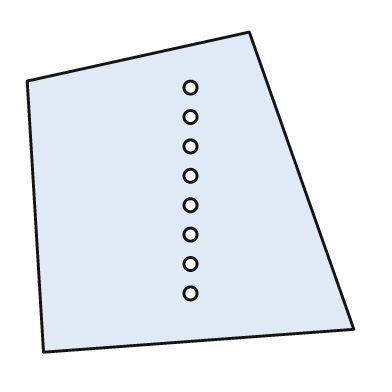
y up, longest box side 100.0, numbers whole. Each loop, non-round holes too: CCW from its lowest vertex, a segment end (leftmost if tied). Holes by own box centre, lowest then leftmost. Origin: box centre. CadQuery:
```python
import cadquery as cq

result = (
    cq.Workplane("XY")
    .moveTo(-45.0, -49.0)
    .lineTo(50.0, -42.0)
    .lineTo(18.0, 49.0)
    .lineTo(-50.0, 34.0)
    .close()
    .moveTo(0.0, -31.0)
    .circle(2.0)
    .moveTo(0.0, -22.0)
    .circle(2.0)
    .moveTo(0.0, -13.0)
    .circle(2.0)
    .moveTo(0.0, -4.0)
    .circle(2.0)
    .moveTo(0.0, 5.0)
    .circle(2.0)
    .moveTo(0.0, 14.0)
    .circle(2.0)
    .moveTo(0.0, 23.0)
    .circle(2.0)
    .moveTo(0.0, 32.0)
    .circle(2.0)
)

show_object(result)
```